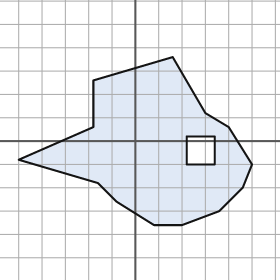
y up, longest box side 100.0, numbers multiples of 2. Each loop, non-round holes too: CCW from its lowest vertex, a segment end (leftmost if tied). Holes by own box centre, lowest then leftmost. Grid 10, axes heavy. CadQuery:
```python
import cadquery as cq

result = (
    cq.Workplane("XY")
    .moveTo(8.0, -36.0)
    .lineTo(20.0, -36.0)
    .lineTo(36.0, -30.0)
    .lineTo(46.0, -20.0)
    .lineTo(50.0, -10.0)
    .lineTo(40.0, 6.0)
    .lineTo(30.0, 12.0)
    .lineTo(16.0, 36.0)
    .lineTo(-18.0, 26.0)
    .lineTo(-18.0, 6.0)
    .lineTo(-50.0, -8.0)
    .lineTo(-16.0, -18.0)
    .lineTo(-8.0, -26.0)
    .close()
    .moveTo(22.0, -10.0)
    .lineTo(34.0, -10.0)
    .lineTo(34.0, 2.0)
    .lineTo(22.0, 2.0)
    .close()
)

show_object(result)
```